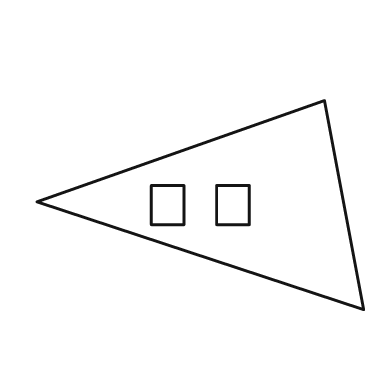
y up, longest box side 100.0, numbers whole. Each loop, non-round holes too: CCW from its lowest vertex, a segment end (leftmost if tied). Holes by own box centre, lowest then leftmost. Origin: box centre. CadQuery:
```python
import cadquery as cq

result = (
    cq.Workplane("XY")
    .moveTo(50.0, -32.0)
    .lineTo(38.0, 32.0)
    .lineTo(-50.0, 1.0)
    .close()
    .moveTo(-15.0, -6.0)
    .lineTo(-5.0, -6.0)
    .lineTo(-5.0, 6.0)
    .lineTo(-15.0, 6.0)
    .close()
    .moveTo(5.0, -6.0)
    .lineTo(15.0, -6.0)
    .lineTo(15.0, 6.0)
    .lineTo(5.0, 6.0)
    .close()
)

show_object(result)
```